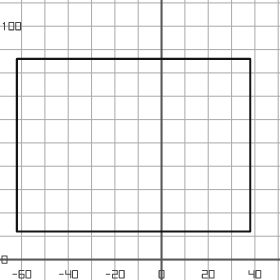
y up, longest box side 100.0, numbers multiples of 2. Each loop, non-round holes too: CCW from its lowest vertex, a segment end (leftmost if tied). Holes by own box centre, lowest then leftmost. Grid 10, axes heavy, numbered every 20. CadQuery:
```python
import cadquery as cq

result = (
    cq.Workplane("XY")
    .moveTo(-62.0, 12.0)
    .lineTo(38.0, 12.0)
    .lineTo(38.0, 86.0)
    .lineTo(-62.0, 86.0)
    .close()
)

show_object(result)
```